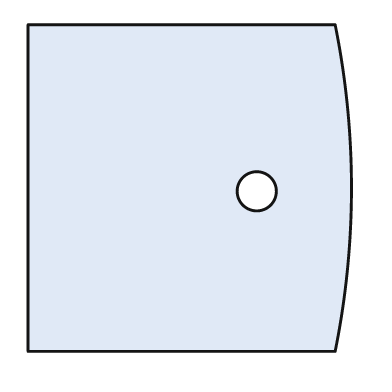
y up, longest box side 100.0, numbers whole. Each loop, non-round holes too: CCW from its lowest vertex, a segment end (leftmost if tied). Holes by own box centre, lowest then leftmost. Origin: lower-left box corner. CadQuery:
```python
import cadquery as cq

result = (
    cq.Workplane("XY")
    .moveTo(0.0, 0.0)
    .lineTo(94.0, 0.0)
    .threePointArc((99.0, 50.0), (94.0, 100.0))
    .lineTo(0.0, 100.0)
    .close()
    .moveTo(70.0, 49.0)
    .circle(6.0)
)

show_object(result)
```